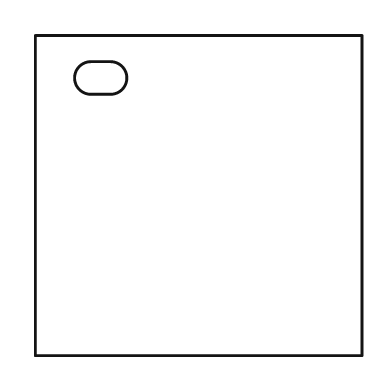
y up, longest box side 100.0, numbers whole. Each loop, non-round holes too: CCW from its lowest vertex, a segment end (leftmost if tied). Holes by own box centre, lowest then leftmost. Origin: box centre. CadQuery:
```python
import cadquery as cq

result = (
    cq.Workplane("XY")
    .moveTo(-50.0, -49.0)
    .lineTo(50.0, -49.0)
    .lineTo(50.0, 49.0)
    .lineTo(-50.0, 49.0)
    .close()
    .moveTo(-33.0, 31.0)
    .lineTo(-27.0, 31.0)
    .threePointArc((-22.0, 36.0), (-27.0, 41.0))
    .lineTo(-33.0, 41.0)
    .threePointArc((-38.0, 36.0), (-33.0, 31.0))
    .close()
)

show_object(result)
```